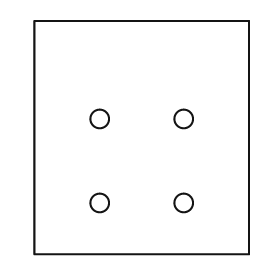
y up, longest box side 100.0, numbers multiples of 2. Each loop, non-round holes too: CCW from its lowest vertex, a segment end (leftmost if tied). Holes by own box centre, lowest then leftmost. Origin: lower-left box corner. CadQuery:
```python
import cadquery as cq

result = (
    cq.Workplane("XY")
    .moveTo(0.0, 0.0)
    .lineTo(92.0, 0.0)
    .lineTo(92.0, 100.0)
    .lineTo(0.0, 100.0)
    .close()
    .moveTo(28.0, 22.0)
    .circle(4.0)
    .moveTo(64.0, 22.0)
    .circle(4.0)
    .moveTo(28.0, 58.0)
    .circle(4.0)
    .moveTo(64.0, 58.0)
    .circle(4.0)
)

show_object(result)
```